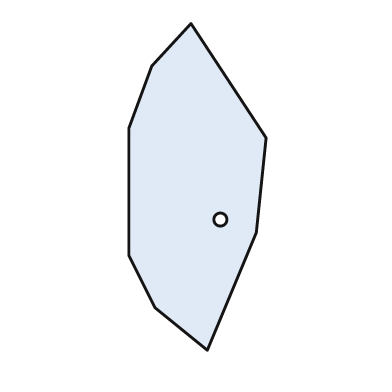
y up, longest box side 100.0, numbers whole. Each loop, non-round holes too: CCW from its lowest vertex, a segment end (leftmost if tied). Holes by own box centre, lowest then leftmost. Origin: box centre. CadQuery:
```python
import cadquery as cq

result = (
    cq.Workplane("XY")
    .moveTo(3.0, -50.0)
    .lineTo(18.0, -14.0)
    .lineTo(21.0, 15.0)
    .lineTo(-2.0, 50.0)
    .lineTo(-14.0, 37.0)
    .lineTo(-21.0, 18.0)
    .lineTo(-21.0, -21.0)
    .lineTo(-13.0, -37.0)
    .close()
    .moveTo(7.0, -10.0)
    .circle(2.0)
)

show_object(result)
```